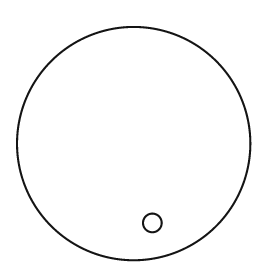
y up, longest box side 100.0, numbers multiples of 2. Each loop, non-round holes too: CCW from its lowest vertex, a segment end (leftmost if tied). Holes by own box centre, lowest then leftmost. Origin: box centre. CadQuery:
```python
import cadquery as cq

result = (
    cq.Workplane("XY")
    .moveTo(0.0, 0.0)
    .circle(50.0)
    .moveTo(8.0, -34.0)
    .circle(4.0)
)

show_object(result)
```